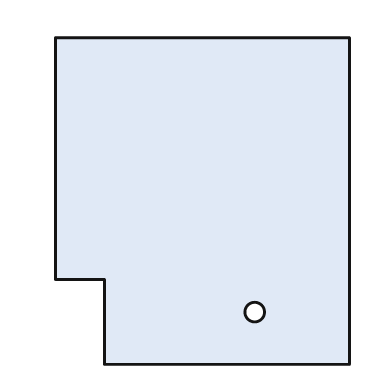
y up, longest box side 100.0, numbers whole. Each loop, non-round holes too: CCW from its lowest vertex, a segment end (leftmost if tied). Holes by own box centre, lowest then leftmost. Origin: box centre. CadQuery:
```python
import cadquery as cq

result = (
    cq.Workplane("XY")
    .moveTo(-30.0, -50.0)
    .lineTo(45.0, -50.0)
    .lineTo(45.0, 50.0)
    .lineTo(-45.0, 50.0)
    .lineTo(-45.0, -24.0)
    .lineTo(-30.0, -24.0)
    .close()
    .moveTo(16.0, -34.0)
    .circle(3.0)
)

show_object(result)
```